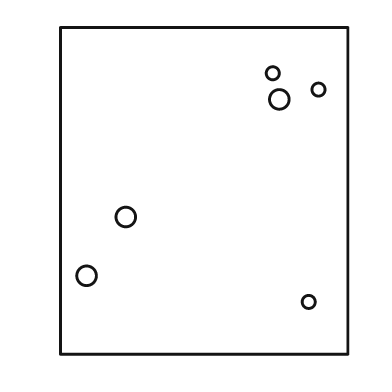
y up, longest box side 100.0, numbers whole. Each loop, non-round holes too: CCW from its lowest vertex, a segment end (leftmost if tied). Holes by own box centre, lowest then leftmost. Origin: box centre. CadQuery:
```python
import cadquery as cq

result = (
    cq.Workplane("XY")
    .moveTo(-44.0, -50.0)
    .lineTo(44.0, -50.0)
    .lineTo(44.0, 50.0)
    .lineTo(-44.0, 50.0)
    .close()
    .moveTo(32.0, -34.0)
    .circle(2.0)
    .moveTo(-36.0, -26.0)
    .circle(3.0)
    .moveTo(-24.0, -8.0)
    .circle(3.0)
    .moveTo(23.0, 28.0)
    .circle(3.0)
    .moveTo(35.0, 31.0)
    .circle(2.0)
    .moveTo(21.0, 36.0)
    .circle(2.0)
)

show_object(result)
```